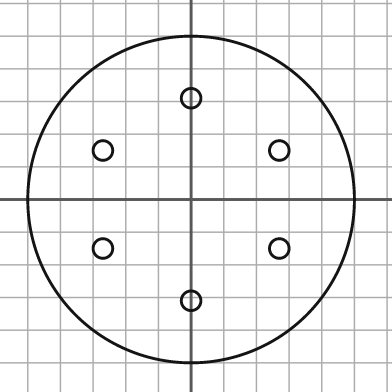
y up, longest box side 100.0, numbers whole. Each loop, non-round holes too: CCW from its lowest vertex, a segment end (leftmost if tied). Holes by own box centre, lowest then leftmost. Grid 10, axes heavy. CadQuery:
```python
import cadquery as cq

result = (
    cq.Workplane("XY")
    .moveTo(0.0, 0.0)
    .circle(50.0)
    .moveTo(0.0, -31.0)
    .circle(3.0)
    .moveTo(-27.0, -15.0)
    .circle(3.0)
    .moveTo(27.0, -15.0)
    .circle(3.0)
    .moveTo(-27.0, 15.0)
    .circle(3.0)
    .moveTo(27.0, 15.0)
    .circle(3.0)
    .moveTo(0.0, 31.0)
    .circle(3.0)
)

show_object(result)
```